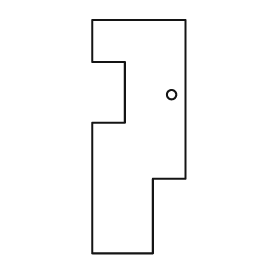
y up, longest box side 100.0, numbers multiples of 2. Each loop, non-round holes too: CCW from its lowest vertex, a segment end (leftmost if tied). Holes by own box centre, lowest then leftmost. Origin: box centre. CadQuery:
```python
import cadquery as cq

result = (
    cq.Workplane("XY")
    .moveTo(-20.0, -50.0)
    .lineTo(6.0, -50.0)
    .lineTo(6.0, -18.0)
    .lineTo(20.0, -18.0)
    .lineTo(20.0, 50.0)
    .lineTo(-20.0, 50.0)
    .lineTo(-20.0, 32.0)
    .lineTo(-6.0, 32.0)
    .lineTo(-6.0, 6.0)
    .lineTo(-20.0, 6.0)
    .close()
    .moveTo(14.0, 18.0)
    .circle(2.0)
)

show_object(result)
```